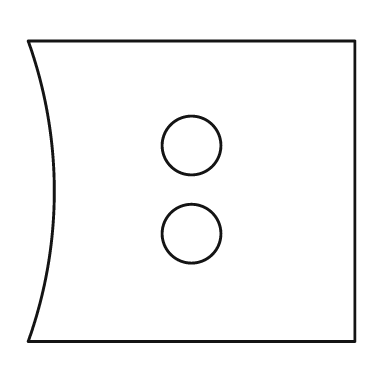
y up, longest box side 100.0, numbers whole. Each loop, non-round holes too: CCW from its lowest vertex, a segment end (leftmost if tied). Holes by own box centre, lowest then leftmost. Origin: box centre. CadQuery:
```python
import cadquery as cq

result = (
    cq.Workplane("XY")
    .moveTo(-50.0, -46.0)
    .lineTo(50.0, -46.0)
    .lineTo(50.0, 46.0)
    .lineTo(-50.0, 46.0)
    .threePointArc((-42.0, 0.0), (-50.0, -46.0))
    .close()
    .moveTo(0.0, -13.0)
    .circle(9.0)
    .moveTo(0.0, 14.0)
    .circle(9.0)
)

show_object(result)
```